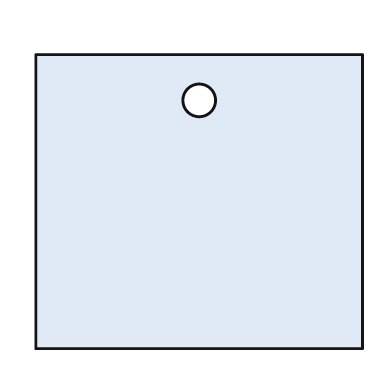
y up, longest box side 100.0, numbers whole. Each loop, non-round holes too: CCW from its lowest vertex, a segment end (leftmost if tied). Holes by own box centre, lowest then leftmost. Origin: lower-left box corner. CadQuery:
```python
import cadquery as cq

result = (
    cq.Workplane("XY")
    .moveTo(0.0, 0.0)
    .lineTo(100.0, 0.0)
    .lineTo(100.0, 90.0)
    .lineTo(0.0, 90.0)
    .close()
    .moveTo(50.0, 76.0)
    .circle(5.0)
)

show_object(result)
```